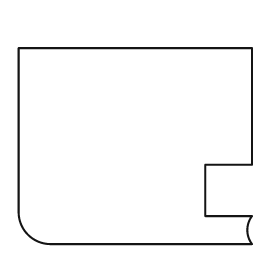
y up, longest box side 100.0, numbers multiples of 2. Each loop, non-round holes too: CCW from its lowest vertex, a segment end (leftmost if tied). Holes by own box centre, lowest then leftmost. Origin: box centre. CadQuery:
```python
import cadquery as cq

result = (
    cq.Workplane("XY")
    .moveTo(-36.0, -42.0)
    .lineTo(50.0, -42.0)
    .threePointArc((48.0, -36.0), (50.0, -30.0))
    .lineTo(30.0, -30.0)
    .lineTo(30.0, -8.0)
    .lineTo(50.0, -8.0)
    .lineTo(50.0, 42.0)
    .lineTo(-50.0, 42.0)
    .lineTo(-50.0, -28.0)
    .threePointArc((-46.0, -38.0), (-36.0, -42.0))
    .close()
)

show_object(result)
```